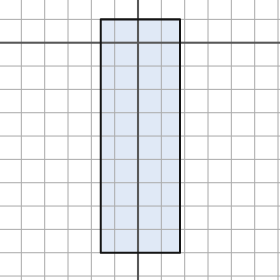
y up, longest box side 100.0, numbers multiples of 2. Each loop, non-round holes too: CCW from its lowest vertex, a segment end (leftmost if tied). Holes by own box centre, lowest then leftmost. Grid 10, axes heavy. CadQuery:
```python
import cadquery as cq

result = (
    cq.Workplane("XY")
    .moveTo(-16.0, -90.0)
    .lineTo(18.0, -90.0)
    .lineTo(18.0, 10.0)
    .lineTo(-16.0, 10.0)
    .close()
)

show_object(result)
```